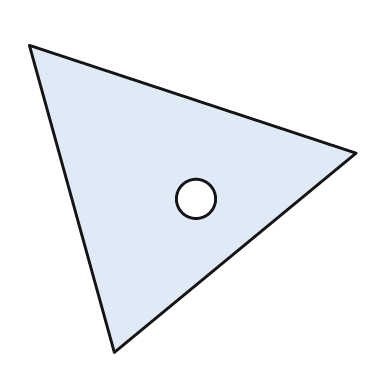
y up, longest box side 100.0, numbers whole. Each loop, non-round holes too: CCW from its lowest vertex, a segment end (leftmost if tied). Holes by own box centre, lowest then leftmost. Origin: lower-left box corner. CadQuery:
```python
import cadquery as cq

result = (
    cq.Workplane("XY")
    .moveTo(26.0, 0.0)
    .lineTo(100.0, 61.0)
    .lineTo(0.0, 94.0)
    .close()
    .moveTo(51.0, 47.0)
    .circle(6.0)
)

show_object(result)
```